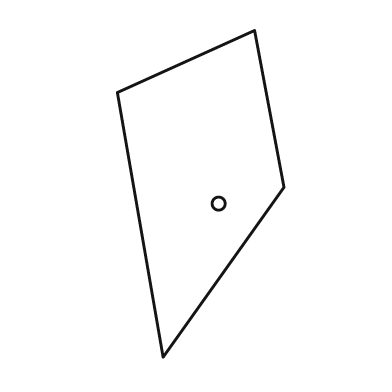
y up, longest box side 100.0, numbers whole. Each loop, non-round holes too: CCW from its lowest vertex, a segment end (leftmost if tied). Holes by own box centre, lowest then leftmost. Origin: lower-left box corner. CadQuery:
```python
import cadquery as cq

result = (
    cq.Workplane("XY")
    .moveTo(14.0, 0.0)
    .lineTo(51.0, 52.0)
    .lineTo(42.0, 100.0)
    .lineTo(0.0, 81.0)
    .close()
    .moveTo(31.0, 47.0)
    .circle(2.0)
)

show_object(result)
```